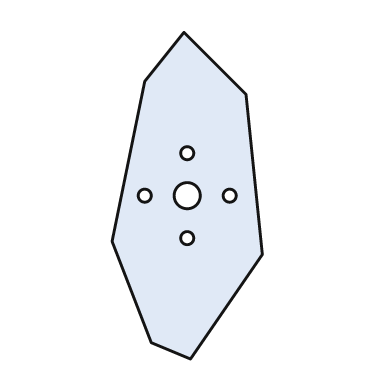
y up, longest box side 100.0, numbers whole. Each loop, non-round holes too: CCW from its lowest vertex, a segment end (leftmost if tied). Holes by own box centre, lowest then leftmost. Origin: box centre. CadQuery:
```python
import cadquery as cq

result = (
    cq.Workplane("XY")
    .moveTo(1.0, -50.0)
    .lineTo(23.0, -18.0)
    .lineTo(18.0, 31.0)
    .lineTo(-1.0, 50.0)
    .lineTo(-13.0, 35.0)
    .lineTo(-23.0, -14.0)
    .lineTo(-11.0, -45.0)
    .close()
    .moveTo(0.0, -13.0)
    .circle(2.0)
    .moveTo(-13.0, 0.0)
    .circle(2.0)
    .moveTo(0.0, 0.0)
    .circle(4.0)
    .moveTo(13.0, 0.0)
    .circle(2.0)
    .moveTo(0.0, 13.0)
    .circle(2.0)
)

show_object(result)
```